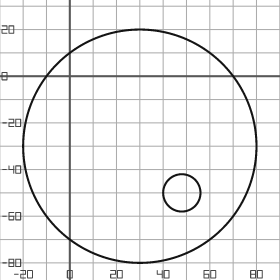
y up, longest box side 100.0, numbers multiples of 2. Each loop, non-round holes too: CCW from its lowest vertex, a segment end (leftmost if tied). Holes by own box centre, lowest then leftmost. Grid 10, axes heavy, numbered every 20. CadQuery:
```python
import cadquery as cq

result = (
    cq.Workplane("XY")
    .moveTo(30.0, -30.0)
    .circle(50.0)
    .moveTo(48.0, -50.0)
    .circle(8.0)
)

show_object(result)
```